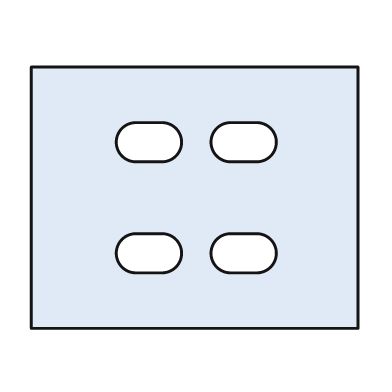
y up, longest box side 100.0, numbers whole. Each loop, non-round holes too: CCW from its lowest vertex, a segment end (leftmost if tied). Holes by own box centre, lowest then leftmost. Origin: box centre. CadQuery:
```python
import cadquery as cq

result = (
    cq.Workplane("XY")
    .moveTo(-50.0, -40.0)
    .lineTo(50.0, -40.0)
    .lineTo(50.0, 40.0)
    .lineTo(-50.0, 40.0)
    .close()
    .moveTo(-18.0, -23.0)
    .lineTo(-10.0, -23.0)
    .threePointArc((-4.0, -17.0), (-10.0, -11.0))
    .lineTo(-18.0, -11.0)
    .threePointArc((-24.0, -17.0), (-18.0, -23.0))
    .close()
    .moveTo(11.0, -23.0)
    .lineTo(19.0, -23.0)
    .threePointArc((25.0, -17.0), (19.0, -11.0))
    .lineTo(11.0, -11.0)
    .threePointArc((5.0, -17.0), (11.0, -23.0))
    .close()
    .moveTo(-18.0, 11.0)
    .lineTo(-10.0, 11.0)
    .threePointArc((-4.0, 17.0), (-10.0, 23.0))
    .lineTo(-18.0, 23.0)
    .threePointArc((-24.0, 17.0), (-18.0, 11.0))
    .close()
    .moveTo(11.0, 11.0)
    .lineTo(19.0, 11.0)
    .threePointArc((25.0, 17.0), (19.0, 23.0))
    .lineTo(11.0, 23.0)
    .threePointArc((5.0, 17.0), (11.0, 11.0))
    .close()
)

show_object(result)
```